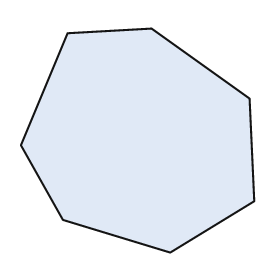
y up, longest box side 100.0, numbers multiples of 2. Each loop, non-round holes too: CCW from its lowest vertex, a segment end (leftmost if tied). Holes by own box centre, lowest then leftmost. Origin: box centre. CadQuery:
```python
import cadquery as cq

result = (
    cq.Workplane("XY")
    .moveTo(14.0, -48.0)
    .lineTo(50.0, -26.0)
    .lineTo(48.0, 18.0)
    .lineTo(6.0, 48.0)
    .lineTo(-30.0, 46.0)
    .lineTo(-50.0, -2.0)
    .lineTo(-32.0, -34.0)
    .close()
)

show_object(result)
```